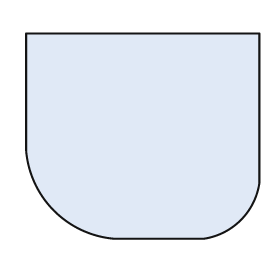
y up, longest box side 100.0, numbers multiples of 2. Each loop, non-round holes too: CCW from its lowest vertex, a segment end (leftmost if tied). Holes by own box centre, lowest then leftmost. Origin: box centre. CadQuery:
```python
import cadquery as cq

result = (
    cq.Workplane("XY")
    .moveTo(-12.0, -44.0)
    .lineTo(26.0, -44.0)
    .threePointArc((42.0, -36.0), (50.0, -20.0))
    .lineTo(50.0, 44.0)
    .lineTo(-50.0, 44.0)
    .lineTo(-50.0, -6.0)
    .threePointArc((-38.0, -32.0), (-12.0, -44.0))
    .close()
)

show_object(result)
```